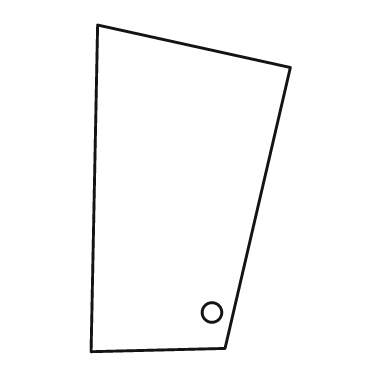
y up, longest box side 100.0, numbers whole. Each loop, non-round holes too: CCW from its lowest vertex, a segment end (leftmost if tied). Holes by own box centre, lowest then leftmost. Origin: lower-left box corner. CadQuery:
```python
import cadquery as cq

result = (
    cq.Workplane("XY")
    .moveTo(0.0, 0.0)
    .lineTo(41.0, 1.0)
    .lineTo(61.0, 87.0)
    .lineTo(2.0, 100.0)
    .close()
    .moveTo(37.0, 12.0)
    .circle(3.0)
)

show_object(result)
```